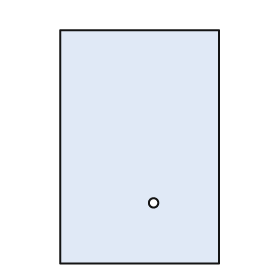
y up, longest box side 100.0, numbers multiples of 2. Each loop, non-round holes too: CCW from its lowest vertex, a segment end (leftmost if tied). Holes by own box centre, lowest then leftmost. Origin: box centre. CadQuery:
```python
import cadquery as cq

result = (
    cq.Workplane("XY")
    .moveTo(-34.0, -50.0)
    .lineTo(34.0, -50.0)
    .lineTo(34.0, 50.0)
    .lineTo(-34.0, 50.0)
    .close()
    .moveTo(6.0, -24.0)
    .circle(2.0)
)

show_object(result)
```